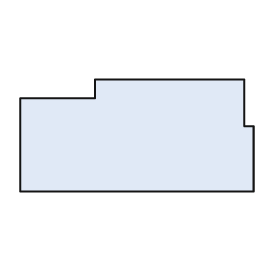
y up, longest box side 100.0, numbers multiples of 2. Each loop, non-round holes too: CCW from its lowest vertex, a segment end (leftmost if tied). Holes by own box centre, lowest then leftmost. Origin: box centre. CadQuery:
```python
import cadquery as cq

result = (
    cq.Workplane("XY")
    .moveTo(-50.0, -24.0)
    .lineTo(50.0, -24.0)
    .lineTo(50.0, 4.0)
    .lineTo(46.0, 4.0)
    .lineTo(46.0, 24.0)
    .lineTo(-18.0, 24.0)
    .lineTo(-18.0, 16.0)
    .lineTo(-50.0, 16.0)
    .close()
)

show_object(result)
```